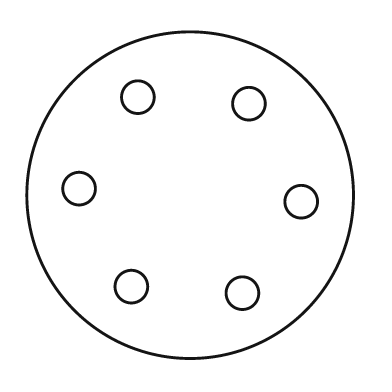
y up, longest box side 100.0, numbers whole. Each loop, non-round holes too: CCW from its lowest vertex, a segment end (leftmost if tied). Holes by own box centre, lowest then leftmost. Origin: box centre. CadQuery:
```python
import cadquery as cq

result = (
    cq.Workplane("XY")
    .moveTo(0.0, 0.0)
    .circle(50.0)
    .moveTo(16.0, -30.0)
    .circle(5.0)
    .moveTo(-18.0, -28.0)
    .circle(5.0)
    .moveTo(34.0, -2.0)
    .circle(5.0)
    .moveTo(-34.0, 2.0)
    .circle(5.0)
    .moveTo(18.0, 28.0)
    .circle(5.0)
    .moveTo(-16.0, 30.0)
    .circle(5.0)
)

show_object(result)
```